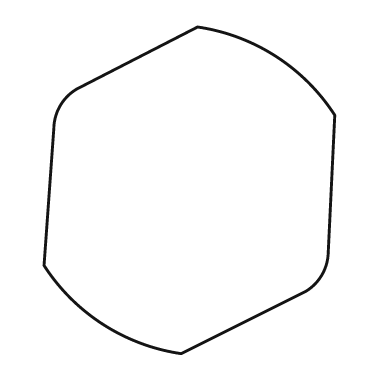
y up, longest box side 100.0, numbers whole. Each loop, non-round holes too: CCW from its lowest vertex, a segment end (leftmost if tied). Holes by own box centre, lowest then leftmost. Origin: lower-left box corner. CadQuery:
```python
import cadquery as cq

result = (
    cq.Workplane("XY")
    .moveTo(42.0, 0.0)
    .lineTo(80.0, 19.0)
    .threePointArc((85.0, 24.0), (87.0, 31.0))
    .lineTo(89.0, 73.0)
    .threePointArc((71.0, 91.0), (47.0, 100.0))
    .lineTo(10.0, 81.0)
    .threePointArc((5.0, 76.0), (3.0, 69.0))
    .lineTo(0.0, 27.0)
    .threePointArc((18.0, 9.0), (42.0, 0.0))
    .close()
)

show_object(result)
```